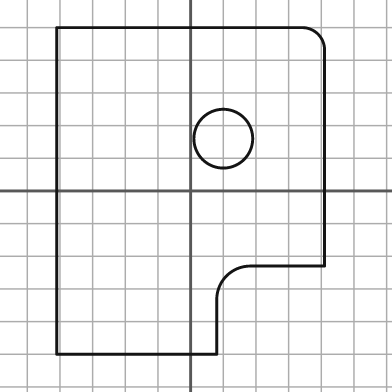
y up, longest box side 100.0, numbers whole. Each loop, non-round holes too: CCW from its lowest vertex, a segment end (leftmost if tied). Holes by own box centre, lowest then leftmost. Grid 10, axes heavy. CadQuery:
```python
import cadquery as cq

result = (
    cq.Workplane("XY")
    .moveTo(-41.0, -50.0)
    .lineTo(8.0, -50.0)
    .lineTo(8.0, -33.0)
    .threePointArc((11.0, -26.0), (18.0, -23.0))
    .lineTo(41.0, -23.0)
    .lineTo(41.0, 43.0)
    .threePointArc((39.0, 48.0), (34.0, 50.0))
    .lineTo(-41.0, 50.0)
    .close()
    .moveTo(10.0, 16.0)
    .circle(9.0)
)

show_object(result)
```